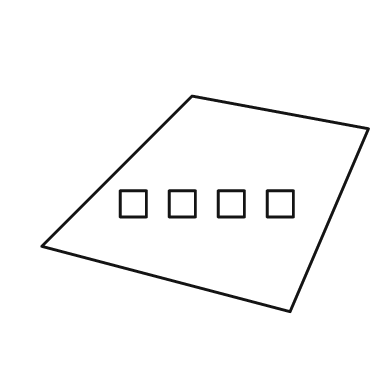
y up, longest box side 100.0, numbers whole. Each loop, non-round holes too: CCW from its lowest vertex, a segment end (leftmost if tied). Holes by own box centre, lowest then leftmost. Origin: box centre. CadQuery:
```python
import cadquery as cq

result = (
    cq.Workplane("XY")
    .moveTo(26.0, -33.0)
    .lineTo(50.0, 23.0)
    .lineTo(-4.0, 33.0)
    .lineTo(-50.0, -13.0)
    .close()
    .moveTo(-26.0, -4.0)
    .lineTo(-18.0, -4.0)
    .lineTo(-18.0, 4.0)
    .lineTo(-26.0, 4.0)
    .close()
    .moveTo(-11.0, -4.0)
    .lineTo(-3.0, -4.0)
    .lineTo(-3.0, 4.0)
    .lineTo(-11.0, 4.0)
    .close()
    .moveTo(4.0, -4.0)
    .lineTo(12.0, -4.0)
    .lineTo(12.0, 4.0)
    .lineTo(4.0, 4.0)
    .close()
    .moveTo(19.0, -4.0)
    .lineTo(27.0, -4.0)
    .lineTo(27.0, 4.0)
    .lineTo(19.0, 4.0)
    .close()
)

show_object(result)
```